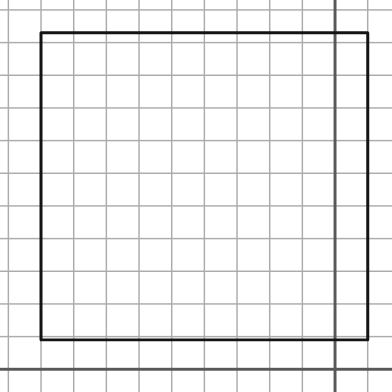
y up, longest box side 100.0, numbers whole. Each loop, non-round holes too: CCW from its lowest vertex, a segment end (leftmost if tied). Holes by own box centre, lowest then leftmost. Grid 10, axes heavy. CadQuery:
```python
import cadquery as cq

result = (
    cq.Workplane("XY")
    .moveTo(-90.0, 9.0)
    .lineTo(10.0, 9.0)
    .lineTo(10.0, 103.0)
    .lineTo(-90.0, 103.0)
    .close()
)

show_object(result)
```